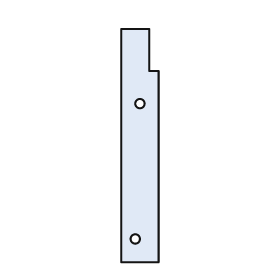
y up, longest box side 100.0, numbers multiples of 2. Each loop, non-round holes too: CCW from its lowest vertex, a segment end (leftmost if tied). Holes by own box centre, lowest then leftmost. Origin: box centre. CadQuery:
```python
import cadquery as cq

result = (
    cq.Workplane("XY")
    .moveTo(-8.0, -50.0)
    .lineTo(8.0, -50.0)
    .lineTo(8.0, 32.0)
    .lineTo(4.0, 32.0)
    .lineTo(4.0, 50.0)
    .lineTo(-8.0, 50.0)
    .close()
    .moveTo(-2.0, -40.0)
    .circle(2.0)
    .moveTo(0.0, 18.0)
    .circle(2.0)
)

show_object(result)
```